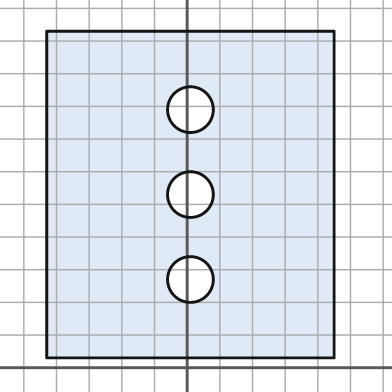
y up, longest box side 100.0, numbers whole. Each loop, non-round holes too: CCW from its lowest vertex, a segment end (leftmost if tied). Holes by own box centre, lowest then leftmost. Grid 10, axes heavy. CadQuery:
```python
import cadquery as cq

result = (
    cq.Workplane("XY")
    .moveTo(-43.0, 3.0)
    .lineTo(45.0, 3.0)
    .lineTo(45.0, 103.0)
    .lineTo(-43.0, 103.0)
    .close()
    .moveTo(1.0, 27.0)
    .circle(7.0)
    .moveTo(1.0, 53.0)
    .circle(7.0)
    .moveTo(1.0, 79.0)
    .circle(7.0)
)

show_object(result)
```